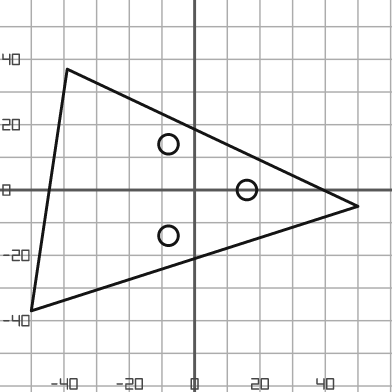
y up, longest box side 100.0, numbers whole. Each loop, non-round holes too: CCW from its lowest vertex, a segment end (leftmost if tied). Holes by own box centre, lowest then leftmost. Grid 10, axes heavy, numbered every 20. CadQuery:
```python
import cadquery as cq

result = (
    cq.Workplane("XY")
    .moveTo(-50.0, -37.0)
    .lineTo(50.0, -5.0)
    .lineTo(-39.0, 37.0)
    .close()
    .moveTo(-8.0, -14.0)
    .circle(3.0)
    .moveTo(16.0, 0.0)
    .circle(3.0)
    .moveTo(-8.0, 14.0)
    .circle(3.0)
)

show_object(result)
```